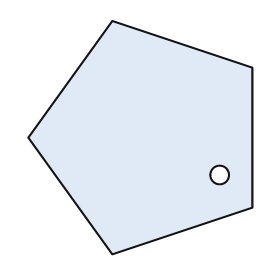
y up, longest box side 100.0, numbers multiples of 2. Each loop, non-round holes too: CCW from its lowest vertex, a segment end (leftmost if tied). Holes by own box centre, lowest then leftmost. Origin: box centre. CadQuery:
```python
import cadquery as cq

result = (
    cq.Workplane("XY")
    .moveTo(-12.0, -50.0)
    .lineTo(48.0, -30.0)
    .lineTo(48.0, 30.0)
    .lineTo(-12.0, 50.0)
    .lineTo(-48.0, 0.0)
    .close()
    .moveTo(34.0, -16.0)
    .circle(4.0)
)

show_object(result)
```